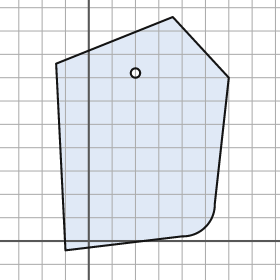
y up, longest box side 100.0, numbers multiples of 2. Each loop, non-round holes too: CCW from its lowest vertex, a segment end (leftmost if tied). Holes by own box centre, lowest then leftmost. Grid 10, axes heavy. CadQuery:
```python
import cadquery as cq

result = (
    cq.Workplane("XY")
    .moveTo(-10.0, -4.0)
    .lineTo(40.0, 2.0)
    .threePointArc((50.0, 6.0), (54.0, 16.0))
    .lineTo(60.0, 70.0)
    .lineTo(36.0, 96.0)
    .lineTo(-14.0, 76.0)
    .close()
    .moveTo(20.0, 72.0)
    .circle(2.0)
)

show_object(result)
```